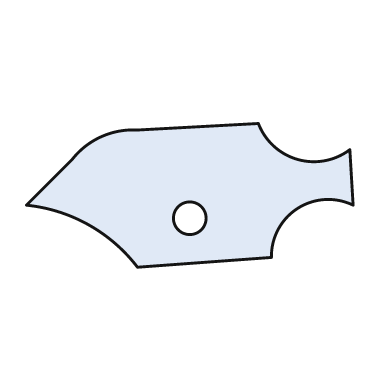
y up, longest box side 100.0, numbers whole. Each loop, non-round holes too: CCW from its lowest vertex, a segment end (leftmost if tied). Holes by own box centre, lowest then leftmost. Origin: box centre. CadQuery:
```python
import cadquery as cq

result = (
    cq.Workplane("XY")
    .moveTo(-16.0, -22.0)
    .lineTo(25.0, -19.0)
    .threePointArc((33.0, -4.0), (50.0, -3.0))
    .lineTo(49.0, 14.0)
    .threePointArc((33.0, 11.0), (21.0, 22.0))
    .lineTo(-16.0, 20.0)
    .threePointArc((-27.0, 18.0), (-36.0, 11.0))
    .lineTo(-50.0, -3.0)
    .threePointArc((-31.0, -9.0), (-16.0, -22.0))
    .close()
    .moveTo(0.0, -7.0)
    .circle(5.0)
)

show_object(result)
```